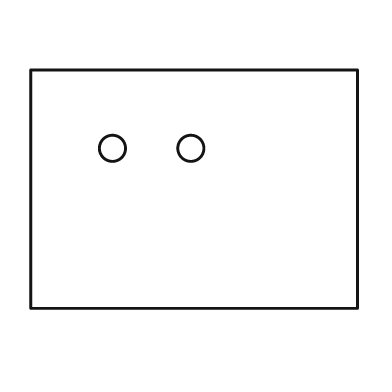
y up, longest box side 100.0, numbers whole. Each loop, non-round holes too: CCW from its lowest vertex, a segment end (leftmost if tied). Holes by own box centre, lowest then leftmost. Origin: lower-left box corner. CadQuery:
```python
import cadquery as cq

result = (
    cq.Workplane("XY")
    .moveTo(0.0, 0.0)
    .lineTo(100.0, 0.0)
    .lineTo(100.0, 73.0)
    .lineTo(0.0, 73.0)
    .close()
    .moveTo(25.0, 49.0)
    .circle(4.0)
    .moveTo(49.0, 49.0)
    .circle(4.0)
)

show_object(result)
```